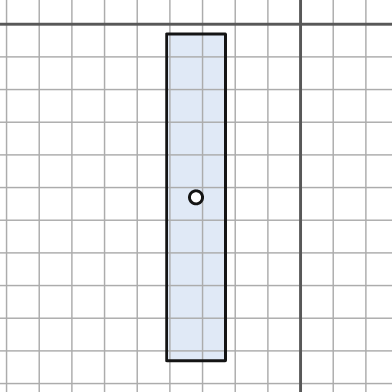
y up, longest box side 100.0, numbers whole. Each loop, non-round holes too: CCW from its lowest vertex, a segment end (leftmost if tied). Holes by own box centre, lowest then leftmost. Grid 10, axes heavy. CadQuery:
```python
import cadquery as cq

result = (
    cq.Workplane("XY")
    .moveTo(-41.0, -103.0)
    .lineTo(-23.0, -103.0)
    .lineTo(-23.0, -3.0)
    .lineTo(-41.0, -3.0)
    .close()
    .moveTo(-32.0, -53.0)
    .circle(2.0)
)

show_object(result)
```